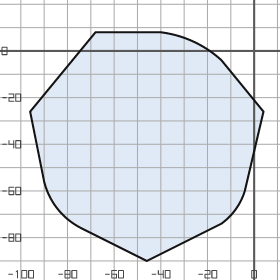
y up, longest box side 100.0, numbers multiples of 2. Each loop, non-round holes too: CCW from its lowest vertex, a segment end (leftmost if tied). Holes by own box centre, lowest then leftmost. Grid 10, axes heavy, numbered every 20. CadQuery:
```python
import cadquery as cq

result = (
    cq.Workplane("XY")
    .moveTo(-46.0, -90.0)
    .lineTo(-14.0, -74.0)
    .threePointArc((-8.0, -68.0), (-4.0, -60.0))
    .lineTo(4.0, -26.0)
    .lineTo(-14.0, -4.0)
    .threePointArc((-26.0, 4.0), (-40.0, 8.0))
    .lineTo(-68.0, 8.0)
    .lineTo(-96.0, -26.0)
    .lineTo(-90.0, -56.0)
    .threePointArc((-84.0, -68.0), (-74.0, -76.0))
    .close()
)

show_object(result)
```